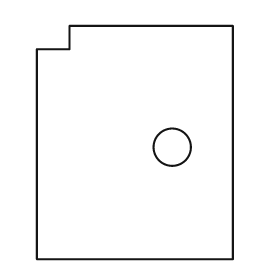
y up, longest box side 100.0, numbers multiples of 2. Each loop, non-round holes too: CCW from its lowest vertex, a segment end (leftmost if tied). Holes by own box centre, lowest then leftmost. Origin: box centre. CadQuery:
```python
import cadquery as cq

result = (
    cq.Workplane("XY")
    .moveTo(-42.0, -50.0)
    .lineTo(42.0, -50.0)
    .lineTo(42.0, 50.0)
    .lineTo(-28.0, 50.0)
    .lineTo(-28.0, 40.0)
    .lineTo(-42.0, 40.0)
    .close()
    .moveTo(16.0, -2.0)
    .circle(8.0)
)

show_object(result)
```